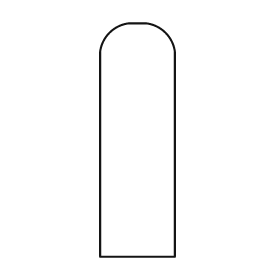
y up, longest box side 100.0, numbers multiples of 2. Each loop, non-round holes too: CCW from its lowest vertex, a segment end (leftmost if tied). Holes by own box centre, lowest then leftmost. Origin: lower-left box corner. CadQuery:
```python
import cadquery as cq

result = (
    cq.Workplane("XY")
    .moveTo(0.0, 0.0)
    .lineTo(32.0, 0.0)
    .lineTo(32.0, 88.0)
    .threePointArc((28.0, 96.0), (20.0, 100.0))
    .lineTo(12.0, 100.0)
    .threePointArc((4.0, 96.0), (0.0, 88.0))
    .close()
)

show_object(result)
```